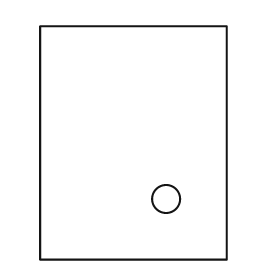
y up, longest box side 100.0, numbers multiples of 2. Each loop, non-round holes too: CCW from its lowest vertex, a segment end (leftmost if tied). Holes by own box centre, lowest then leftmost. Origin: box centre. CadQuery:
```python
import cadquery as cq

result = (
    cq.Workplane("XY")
    .moveTo(-40.0, -50.0)
    .lineTo(40.0, -50.0)
    .lineTo(40.0, 50.0)
    .lineTo(-40.0, 50.0)
    .close()
    .moveTo(14.0, -24.0)
    .circle(6.0)
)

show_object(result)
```